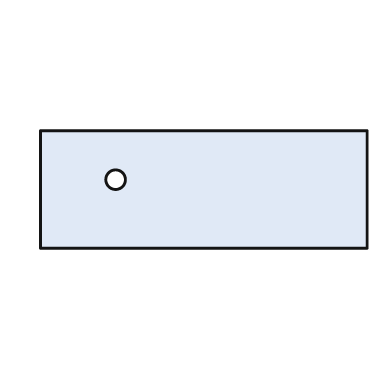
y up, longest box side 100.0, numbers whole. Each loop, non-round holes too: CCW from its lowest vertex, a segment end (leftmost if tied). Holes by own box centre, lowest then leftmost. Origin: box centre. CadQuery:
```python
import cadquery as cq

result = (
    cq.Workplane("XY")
    .moveTo(-50.0, -18.0)
    .lineTo(50.0, -18.0)
    .lineTo(50.0, 18.0)
    .lineTo(-50.0, 18.0)
    .close()
    .moveTo(-27.0, 3.0)
    .circle(3.0)
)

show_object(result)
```